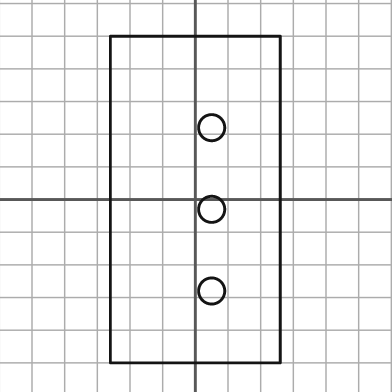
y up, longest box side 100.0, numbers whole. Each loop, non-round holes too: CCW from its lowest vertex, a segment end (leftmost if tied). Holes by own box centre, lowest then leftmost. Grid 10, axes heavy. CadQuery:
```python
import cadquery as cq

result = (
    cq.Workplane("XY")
    .moveTo(-26.0, -50.0)
    .lineTo(26.0, -50.0)
    .lineTo(26.0, 50.0)
    .lineTo(-26.0, 50.0)
    .close()
    .moveTo(5.0, -28.0)
    .circle(4.0)
    .moveTo(5.0, -3.0)
    .circle(4.0)
    .moveTo(5.0, 22.0)
    .circle(4.0)
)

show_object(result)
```